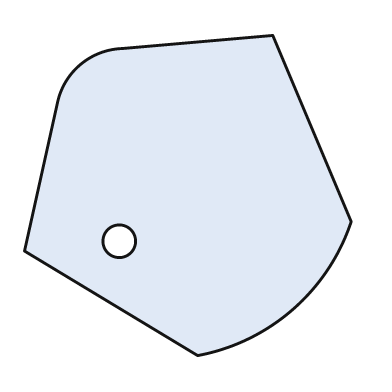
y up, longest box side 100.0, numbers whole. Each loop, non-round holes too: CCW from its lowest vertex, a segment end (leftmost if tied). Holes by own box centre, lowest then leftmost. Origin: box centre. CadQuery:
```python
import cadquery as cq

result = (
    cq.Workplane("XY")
    .moveTo(3.0, -49.0)
    .threePointArc((32.0, -35.0), (50.0, -8.0))
    .lineTo(26.0, 49.0)
    .lineTo(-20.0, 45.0)
    .threePointArc((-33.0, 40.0), (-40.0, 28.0))
    .lineTo(-50.0, -17.0)
    .close()
    .moveTo(-21.0, -14.0)
    .circle(5.0)
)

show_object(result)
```